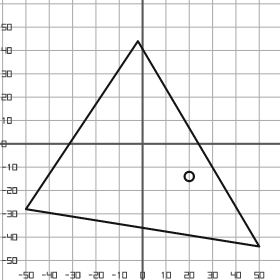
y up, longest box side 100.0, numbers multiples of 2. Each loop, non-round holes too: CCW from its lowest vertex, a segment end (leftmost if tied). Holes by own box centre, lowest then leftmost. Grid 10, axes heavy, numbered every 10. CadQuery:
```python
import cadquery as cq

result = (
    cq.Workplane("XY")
    .moveTo(50.0, -44.0)
    .lineTo(-2.0, 44.0)
    .lineTo(-50.0, -28.0)
    .close()
    .moveTo(20.0, -14.0)
    .circle(2.0)
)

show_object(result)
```